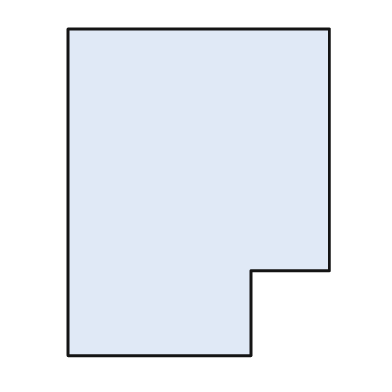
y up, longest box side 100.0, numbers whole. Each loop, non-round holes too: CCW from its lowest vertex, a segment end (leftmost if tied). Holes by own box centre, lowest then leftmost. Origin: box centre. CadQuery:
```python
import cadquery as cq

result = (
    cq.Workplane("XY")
    .moveTo(-40.0, -50.0)
    .lineTo(16.0, -50.0)
    .lineTo(16.0, -24.0)
    .lineTo(40.0, -24.0)
    .lineTo(40.0, 50.0)
    .lineTo(-40.0, 50.0)
    .close()
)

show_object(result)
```